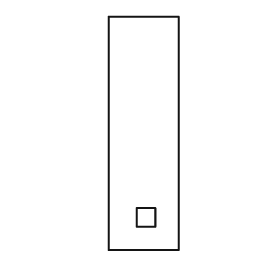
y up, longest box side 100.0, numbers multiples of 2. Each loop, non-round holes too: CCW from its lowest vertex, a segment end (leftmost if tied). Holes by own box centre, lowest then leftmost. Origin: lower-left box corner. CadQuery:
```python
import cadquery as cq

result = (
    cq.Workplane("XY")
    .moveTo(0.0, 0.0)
    .lineTo(30.0, 0.0)
    .lineTo(30.0, 100.0)
    .lineTo(0.0, 100.0)
    .close()
    .moveTo(12.0, 10.0)
    .lineTo(20.0, 10.0)
    .lineTo(20.0, 18.0)
    .lineTo(12.0, 18.0)
    .close()
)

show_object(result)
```